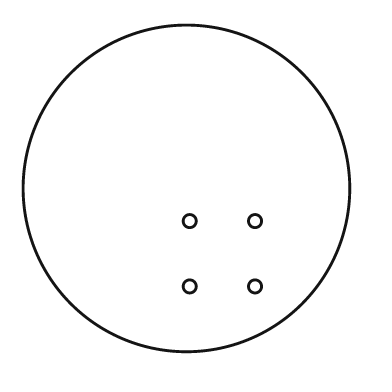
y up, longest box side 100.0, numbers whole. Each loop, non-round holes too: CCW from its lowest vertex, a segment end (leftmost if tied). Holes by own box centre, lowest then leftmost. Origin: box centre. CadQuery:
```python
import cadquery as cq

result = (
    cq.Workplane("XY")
    .moveTo(0.0, 0.0)
    .circle(50.0)
    .moveTo(1.0, -30.0)
    .circle(2.0)
    .moveTo(21.0, -30.0)
    .circle(2.0)
    .moveTo(1.0, -10.0)
    .circle(2.0)
    .moveTo(21.0, -10.0)
    .circle(2.0)
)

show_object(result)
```